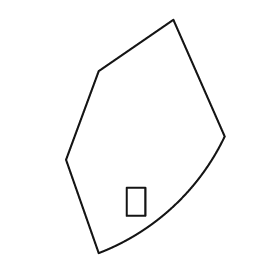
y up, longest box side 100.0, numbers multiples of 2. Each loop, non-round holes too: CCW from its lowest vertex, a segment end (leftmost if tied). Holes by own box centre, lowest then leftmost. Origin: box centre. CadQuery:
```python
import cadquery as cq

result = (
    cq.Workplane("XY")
    .moveTo(-20.0, -50.0)
    .threePointArc((12.0, -30.0), (34.0, 0.0))
    .lineTo(12.0, 50.0)
    .lineTo(-20.0, 28.0)
    .lineTo(-34.0, -10.0)
    .close()
    .moveTo(-8.0, -34.0)
    .lineTo(0.0, -34.0)
    .lineTo(0.0, -22.0)
    .lineTo(-8.0, -22.0)
    .close()
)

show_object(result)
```